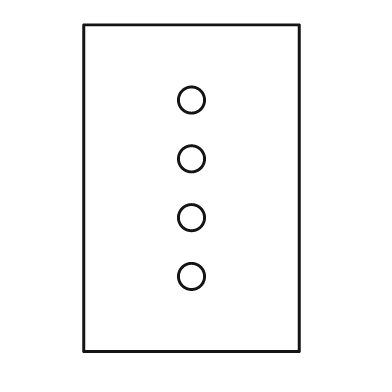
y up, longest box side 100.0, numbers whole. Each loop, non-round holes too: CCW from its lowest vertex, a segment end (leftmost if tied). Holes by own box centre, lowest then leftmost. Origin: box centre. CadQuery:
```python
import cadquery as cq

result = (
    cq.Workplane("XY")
    .moveTo(-33.0, -50.0)
    .lineTo(33.0, -50.0)
    .lineTo(33.0, 50.0)
    .lineTo(-33.0, 50.0)
    .close()
    .moveTo(0.0, -27.0)
    .circle(4.0)
    .moveTo(0.0, -9.0)
    .circle(4.0)
    .moveTo(0.0, 9.0)
    .circle(4.0)
    .moveTo(0.0, 27.0)
    .circle(4.0)
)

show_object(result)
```